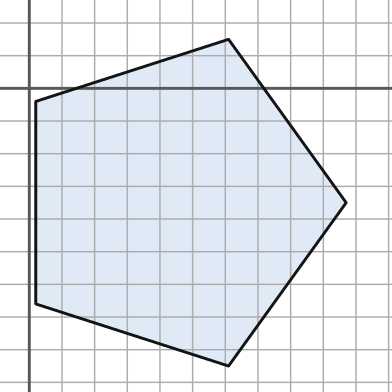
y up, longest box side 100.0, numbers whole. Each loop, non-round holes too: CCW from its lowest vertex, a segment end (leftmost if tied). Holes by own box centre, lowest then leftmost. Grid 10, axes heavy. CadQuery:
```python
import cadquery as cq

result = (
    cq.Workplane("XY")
    .moveTo(61.0, -85.0)
    .lineTo(97.0, -35.0)
    .lineTo(61.0, 15.0)
    .lineTo(2.0, -4.0)
    .lineTo(2.0, -66.0)
    .close()
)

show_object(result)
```